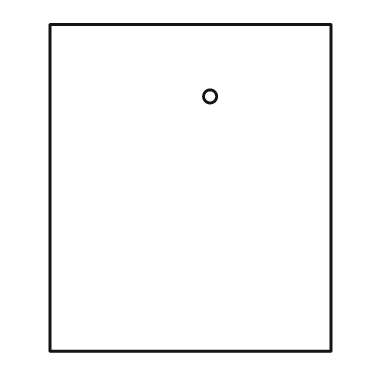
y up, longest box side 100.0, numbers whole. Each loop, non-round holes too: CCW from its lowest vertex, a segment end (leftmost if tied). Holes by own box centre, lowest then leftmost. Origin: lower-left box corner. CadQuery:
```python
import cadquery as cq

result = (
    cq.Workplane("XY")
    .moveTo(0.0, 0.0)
    .lineTo(86.0, 0.0)
    .lineTo(86.0, 100.0)
    .lineTo(0.0, 100.0)
    .close()
    .moveTo(49.0, 78.0)
    .circle(2.0)
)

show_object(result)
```